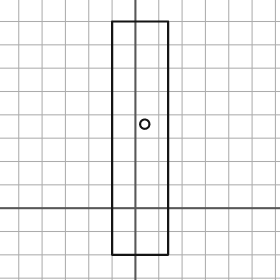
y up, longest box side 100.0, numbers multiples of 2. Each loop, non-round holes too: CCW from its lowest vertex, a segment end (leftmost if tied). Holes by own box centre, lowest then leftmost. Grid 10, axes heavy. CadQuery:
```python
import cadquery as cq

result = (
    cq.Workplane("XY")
    .moveTo(-10.0, -20.0)
    .lineTo(14.0, -20.0)
    .lineTo(14.0, 80.0)
    .lineTo(-10.0, 80.0)
    .close()
    .moveTo(4.0, 36.0)
    .circle(2.0)
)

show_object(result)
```